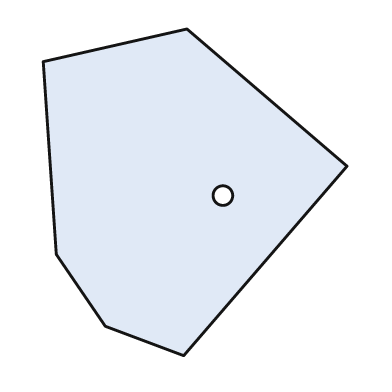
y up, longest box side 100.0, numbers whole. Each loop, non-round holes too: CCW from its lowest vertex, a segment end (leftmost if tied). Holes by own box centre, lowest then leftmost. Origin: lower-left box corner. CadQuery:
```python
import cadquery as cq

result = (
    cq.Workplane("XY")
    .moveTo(43.0, 0.0)
    .lineTo(93.0, 58.0)
    .lineTo(44.0, 100.0)
    .lineTo(0.0, 90.0)
    .lineTo(4.0, 31.0)
    .lineTo(19.0, 9.0)
    .close()
    .moveTo(55.0, 49.0)
    .circle(3.0)
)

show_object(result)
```